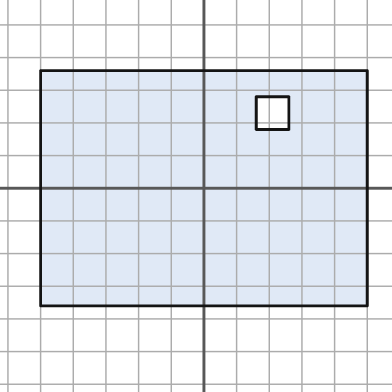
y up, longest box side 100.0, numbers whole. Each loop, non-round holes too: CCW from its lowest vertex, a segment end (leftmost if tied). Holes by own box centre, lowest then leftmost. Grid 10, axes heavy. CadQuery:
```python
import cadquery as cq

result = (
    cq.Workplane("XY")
    .moveTo(-50.0, -36.0)
    .lineTo(50.0, -36.0)
    .lineTo(50.0, 36.0)
    .lineTo(-50.0, 36.0)
    .close()
    .moveTo(16.0, 18.0)
    .lineTo(26.0, 18.0)
    .lineTo(26.0, 28.0)
    .lineTo(16.0, 28.0)
    .close()
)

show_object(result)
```